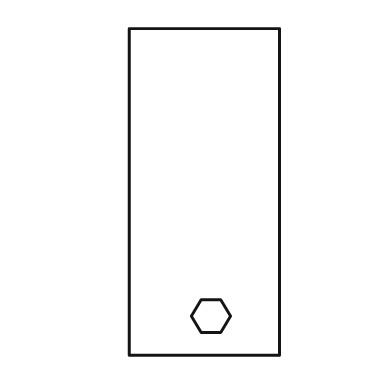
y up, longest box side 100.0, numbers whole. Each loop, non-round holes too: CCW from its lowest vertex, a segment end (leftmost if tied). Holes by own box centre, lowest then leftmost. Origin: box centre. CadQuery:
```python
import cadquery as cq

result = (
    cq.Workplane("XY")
    .moveTo(-23.0, -50.0)
    .lineTo(23.0, -50.0)
    .lineTo(23.0, 50.0)
    .lineTo(-23.0, 50.0)
    .close()
    .moveTo(-1.0, -43.0)
    .lineTo(5.0, -43.0)
    .lineTo(8.0, -38.0)
    .lineTo(5.0, -33.0)
    .lineTo(-1.0, -33.0)
    .lineTo(-4.0, -38.0)
    .close()
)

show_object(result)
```